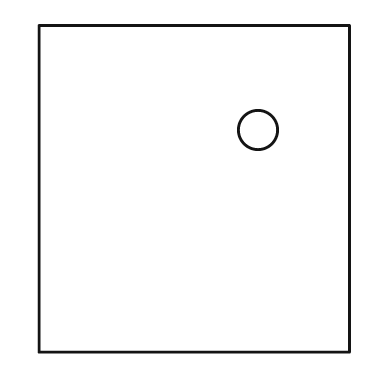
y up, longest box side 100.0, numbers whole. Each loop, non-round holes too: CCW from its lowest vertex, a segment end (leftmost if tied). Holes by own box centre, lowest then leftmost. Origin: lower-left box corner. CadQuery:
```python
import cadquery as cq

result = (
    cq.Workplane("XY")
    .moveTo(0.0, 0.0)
    .lineTo(95.0, 0.0)
    .lineTo(95.0, 100.0)
    .lineTo(0.0, 100.0)
    .close()
    .moveTo(67.0, 68.0)
    .circle(6.0)
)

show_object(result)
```